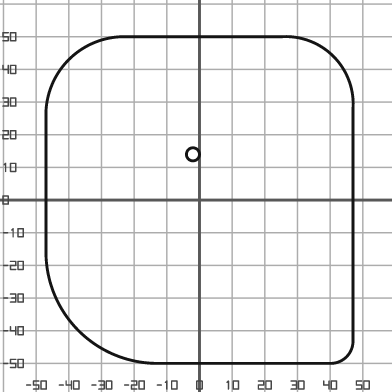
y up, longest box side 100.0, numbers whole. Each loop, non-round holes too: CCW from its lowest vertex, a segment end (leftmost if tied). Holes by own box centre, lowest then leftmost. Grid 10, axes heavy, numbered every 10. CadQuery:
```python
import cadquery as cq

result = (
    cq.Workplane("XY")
    .moveTo(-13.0, -50.0)
    .lineTo(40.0, -50.0)
    .threePointArc((45.0, -48.0), (47.0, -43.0))
    .lineTo(47.0, 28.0)
    .threePointArc((41.0, 44.0), (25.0, 50.0))
    .lineTo(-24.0, 50.0)
    .threePointArc((-40.0, 43.0), (-47.0, 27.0))
    .lineTo(-47.0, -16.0)
    .threePointArc((-37.0, -40.0), (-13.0, -50.0))
    .close()
    .moveTo(-2.0, 14.0)
    .circle(2.0)
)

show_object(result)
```